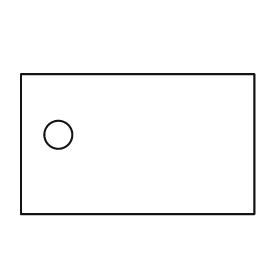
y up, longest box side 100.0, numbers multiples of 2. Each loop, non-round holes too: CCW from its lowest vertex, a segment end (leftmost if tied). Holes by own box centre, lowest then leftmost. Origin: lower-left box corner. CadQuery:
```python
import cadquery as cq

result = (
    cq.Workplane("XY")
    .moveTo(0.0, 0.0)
    .lineTo(100.0, 0.0)
    .lineTo(100.0, 60.0)
    .lineTo(0.0, 60.0)
    .close()
    .moveTo(16.0, 34.0)
    .circle(6.0)
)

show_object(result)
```